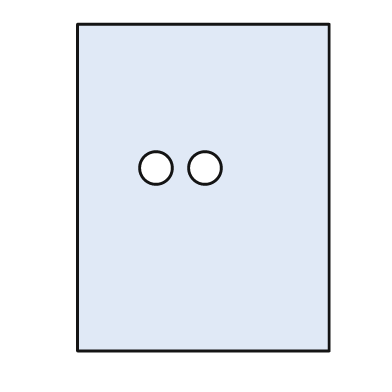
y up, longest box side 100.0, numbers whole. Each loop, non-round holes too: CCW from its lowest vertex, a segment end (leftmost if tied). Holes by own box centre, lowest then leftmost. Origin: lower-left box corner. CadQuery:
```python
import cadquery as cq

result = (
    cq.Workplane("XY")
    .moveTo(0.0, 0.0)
    .lineTo(77.0, 0.0)
    .lineTo(77.0, 100.0)
    .lineTo(0.0, 100.0)
    .close()
    .moveTo(24.0, 56.0)
    .circle(5.0)
    .moveTo(39.0, 56.0)
    .circle(5.0)
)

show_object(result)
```